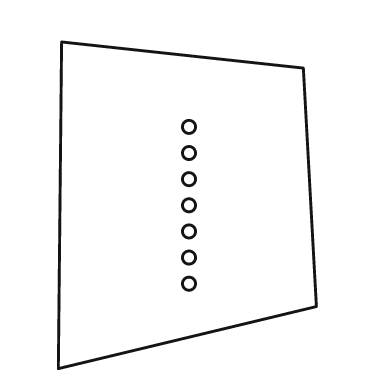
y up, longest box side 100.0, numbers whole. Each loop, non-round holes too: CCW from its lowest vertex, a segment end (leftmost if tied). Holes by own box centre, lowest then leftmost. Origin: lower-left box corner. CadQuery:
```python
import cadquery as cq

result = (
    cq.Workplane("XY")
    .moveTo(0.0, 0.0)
    .lineTo(79.0, 19.0)
    .lineTo(75.0, 92.0)
    .lineTo(1.0, 100.0)
    .close()
    .moveTo(40.0, 26.0)
    .circle(2.0)
    .moveTo(40.0, 34.0)
    .circle(2.0)
    .moveTo(40.0, 42.0)
    .circle(2.0)
    .moveTo(40.0, 50.0)
    .circle(2.0)
    .moveTo(40.0, 58.0)
    .circle(2.0)
    .moveTo(40.0, 66.0)
    .circle(2.0)
    .moveTo(40.0, 74.0)
    .circle(2.0)
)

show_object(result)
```